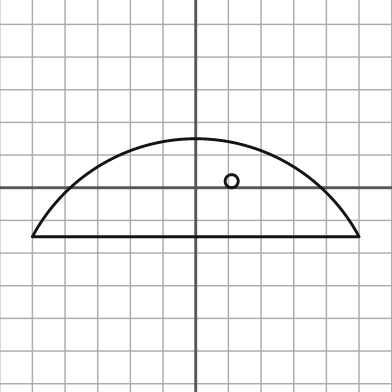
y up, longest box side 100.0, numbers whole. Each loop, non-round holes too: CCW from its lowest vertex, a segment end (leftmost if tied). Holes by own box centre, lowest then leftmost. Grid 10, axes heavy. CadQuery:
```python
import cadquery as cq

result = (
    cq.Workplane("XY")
    .moveTo(-50.0, -15.0)
    .lineTo(50.0, -15.0)
    .threePointArc((0.0, 15.0), (-50.0, -15.0))
    .close()
    .moveTo(11.0, 2.0)
    .circle(2.0)
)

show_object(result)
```